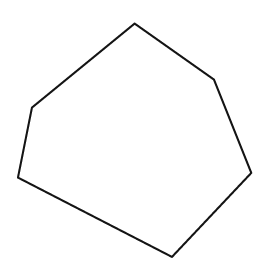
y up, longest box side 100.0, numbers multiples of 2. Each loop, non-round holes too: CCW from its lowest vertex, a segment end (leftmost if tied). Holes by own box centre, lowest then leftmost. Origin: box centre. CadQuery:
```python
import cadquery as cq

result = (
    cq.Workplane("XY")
    .moveTo(16.0, -50.0)
    .lineTo(50.0, -14.0)
    .lineTo(34.0, 26.0)
    .lineTo(0.0, 50.0)
    .lineTo(-44.0, 14.0)
    .lineTo(-50.0, -16.0)
    .close()
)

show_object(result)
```